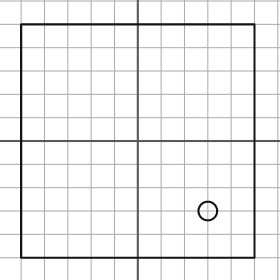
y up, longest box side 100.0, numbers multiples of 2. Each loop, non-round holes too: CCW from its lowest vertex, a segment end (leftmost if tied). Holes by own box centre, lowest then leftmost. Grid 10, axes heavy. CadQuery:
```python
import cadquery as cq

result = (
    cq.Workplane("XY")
    .moveTo(-50.0, -50.0)
    .lineTo(50.0, -50.0)
    .lineTo(50.0, 50.0)
    .lineTo(-50.0, 50.0)
    .close()
    .moveTo(30.0, -30.0)
    .circle(4.0)
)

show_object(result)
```